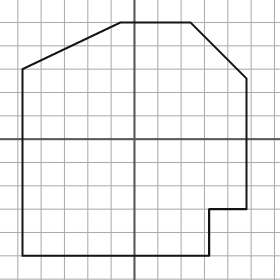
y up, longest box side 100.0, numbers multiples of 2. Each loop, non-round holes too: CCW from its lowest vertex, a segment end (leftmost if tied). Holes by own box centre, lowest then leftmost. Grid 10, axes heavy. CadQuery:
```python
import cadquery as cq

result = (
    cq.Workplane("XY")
    .moveTo(-48.0, -50.0)
    .lineTo(32.0, -50.0)
    .lineTo(32.0, -30.0)
    .lineTo(48.0, -30.0)
    .lineTo(48.0, 26.0)
    .lineTo(24.0, 50.0)
    .lineTo(-6.0, 50.0)
    .lineTo(-48.0, 30.0)
    .close()
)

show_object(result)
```